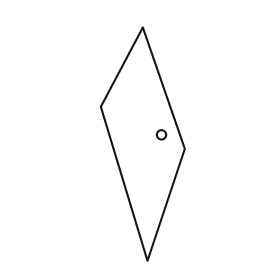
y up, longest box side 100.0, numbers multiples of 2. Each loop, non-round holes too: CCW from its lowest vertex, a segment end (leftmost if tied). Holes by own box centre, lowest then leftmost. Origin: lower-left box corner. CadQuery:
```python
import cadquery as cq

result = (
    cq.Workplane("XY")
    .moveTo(20.0, 0.0)
    .lineTo(36.0, 48.0)
    .lineTo(18.0, 100.0)
    .lineTo(0.0, 66.0)
    .close()
    .moveTo(26.0, 54.0)
    .circle(2.0)
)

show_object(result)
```